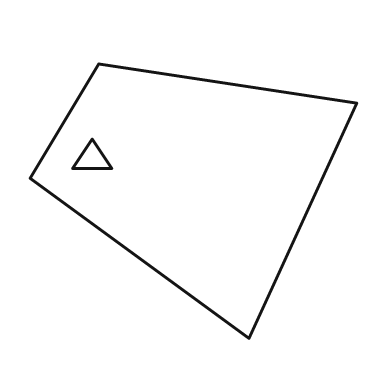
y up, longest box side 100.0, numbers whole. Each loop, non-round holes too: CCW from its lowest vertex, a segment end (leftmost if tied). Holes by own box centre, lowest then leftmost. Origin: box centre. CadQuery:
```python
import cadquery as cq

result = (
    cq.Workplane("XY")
    .moveTo(17.0, -42.0)
    .lineTo(50.0, 30.0)
    .lineTo(-29.0, 42.0)
    .lineTo(-50.0, 7.0)
    .close()
    .moveTo(-37.0, 10.0)
    .lineTo(-25.0, 10.0)
    .lineTo(-31.0, 19.0)
    .close()
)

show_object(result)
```